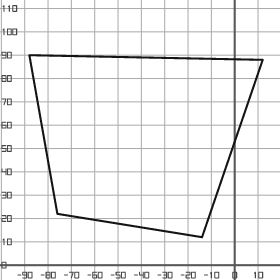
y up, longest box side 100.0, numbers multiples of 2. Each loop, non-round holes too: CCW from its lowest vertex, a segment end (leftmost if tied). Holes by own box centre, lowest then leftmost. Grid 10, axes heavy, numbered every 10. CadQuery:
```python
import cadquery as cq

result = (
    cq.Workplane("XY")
    .moveTo(-14.0, 12.0)
    .lineTo(12.0, 88.0)
    .lineTo(-88.0, 90.0)
    .lineTo(-76.0, 22.0)
    .close()
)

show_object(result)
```